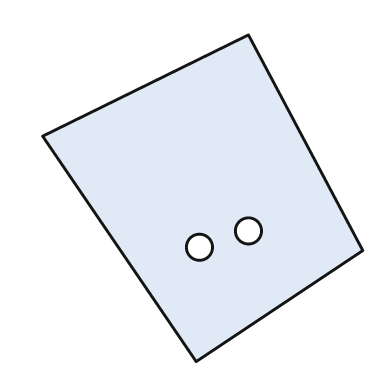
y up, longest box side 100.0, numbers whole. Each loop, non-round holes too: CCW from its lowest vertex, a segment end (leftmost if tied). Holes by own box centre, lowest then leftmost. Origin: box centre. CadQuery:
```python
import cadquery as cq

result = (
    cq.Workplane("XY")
    .moveTo(-2.0, -50.0)
    .lineTo(49.0, -16.0)
    .lineTo(14.0, 50.0)
    .lineTo(-49.0, 19.0)
    .close()
    .moveTo(-1.0, -15.0)
    .circle(4.0)
    .moveTo(14.0, -10.0)
    .circle(4.0)
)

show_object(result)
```